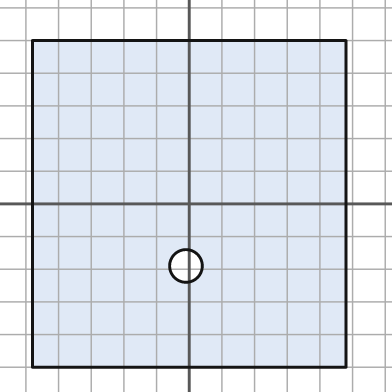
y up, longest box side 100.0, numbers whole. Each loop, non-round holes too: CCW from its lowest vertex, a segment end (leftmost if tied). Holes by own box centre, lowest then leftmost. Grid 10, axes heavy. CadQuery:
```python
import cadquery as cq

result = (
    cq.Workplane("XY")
    .moveTo(-48.0, -50.0)
    .lineTo(48.0, -50.0)
    .lineTo(48.0, 50.0)
    .lineTo(-48.0, 50.0)
    .close()
    .moveTo(-1.0, -19.0)
    .circle(5.0)
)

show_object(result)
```